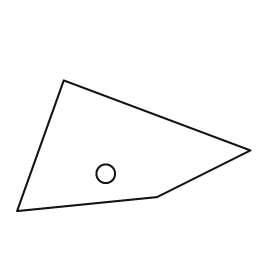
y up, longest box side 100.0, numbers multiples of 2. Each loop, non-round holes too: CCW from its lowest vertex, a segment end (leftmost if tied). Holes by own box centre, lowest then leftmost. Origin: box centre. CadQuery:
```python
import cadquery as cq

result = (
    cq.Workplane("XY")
    .moveTo(-50.0, -28.0)
    .lineTo(10.0, -22.0)
    .lineTo(50.0, -2.0)
    .lineTo(-30.0, 28.0)
    .close()
    .moveTo(-12.0, -12.0)
    .circle(4.0)
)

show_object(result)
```